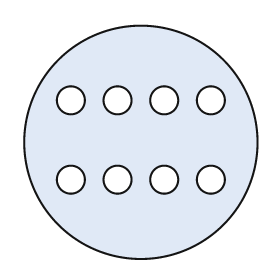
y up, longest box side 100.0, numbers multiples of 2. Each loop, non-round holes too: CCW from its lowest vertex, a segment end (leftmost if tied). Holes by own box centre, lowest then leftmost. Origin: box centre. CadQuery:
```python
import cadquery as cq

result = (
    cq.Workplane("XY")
    .moveTo(0.0, 0.0)
    .circle(50.0)
    .moveTo(-30.0, -16.0)
    .circle(6.0)
    .moveTo(-10.0, -16.0)
    .circle(6.0)
    .moveTo(10.0, -16.0)
    .circle(6.0)
    .moveTo(30.0, -16.0)
    .circle(6.0)
    .moveTo(-30.0, 18.0)
    .circle(6.0)
    .moveTo(-10.0, 18.0)
    .circle(6.0)
    .moveTo(10.0, 18.0)
    .circle(6.0)
    .moveTo(30.0, 18.0)
    .circle(6.0)
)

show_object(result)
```